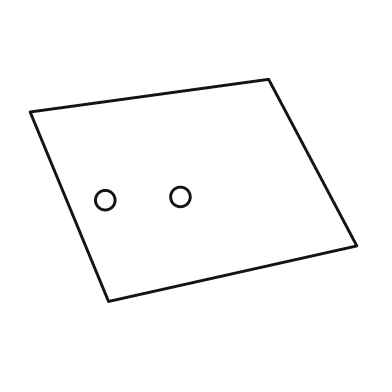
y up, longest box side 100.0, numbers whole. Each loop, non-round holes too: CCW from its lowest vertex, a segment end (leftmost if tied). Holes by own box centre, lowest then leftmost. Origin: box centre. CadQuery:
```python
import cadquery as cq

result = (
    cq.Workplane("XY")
    .moveTo(-26.0, -34.0)
    .lineTo(50.0, -17.0)
    .lineTo(23.0, 34.0)
    .lineTo(-50.0, 24.0)
    .close()
    .moveTo(-27.0, -3.0)
    .circle(3.0)
    .moveTo(-4.0, -2.0)
    .circle(3.0)
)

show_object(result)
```